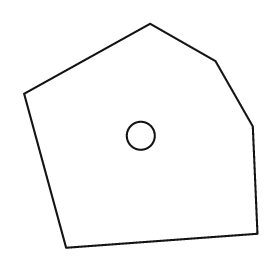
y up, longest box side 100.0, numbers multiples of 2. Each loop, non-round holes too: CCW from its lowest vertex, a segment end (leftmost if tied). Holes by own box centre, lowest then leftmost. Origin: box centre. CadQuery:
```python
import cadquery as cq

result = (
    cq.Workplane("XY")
    .moveTo(-32.0, -48.0)
    .lineTo(50.0, -42.0)
    .lineTo(48.0, 4.0)
    .lineTo(32.0, 32.0)
    .lineTo(4.0, 48.0)
    .lineTo(-50.0, 18.0)
    .close()
    .moveTo(0.0, 0.0)
    .circle(6.0)
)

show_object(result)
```